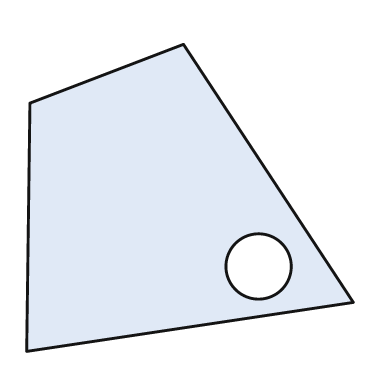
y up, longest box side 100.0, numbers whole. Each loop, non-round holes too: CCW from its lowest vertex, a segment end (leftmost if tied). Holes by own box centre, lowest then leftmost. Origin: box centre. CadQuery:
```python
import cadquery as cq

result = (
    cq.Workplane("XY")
    .moveTo(-50.0, -47.0)
    .lineTo(50.0, -32.0)
    .lineTo(-2.0, 47.0)
    .lineTo(-49.0, 29.0)
    .close()
    .moveTo(21.0, -21.0)
    .circle(10.0)
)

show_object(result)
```